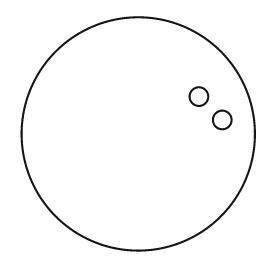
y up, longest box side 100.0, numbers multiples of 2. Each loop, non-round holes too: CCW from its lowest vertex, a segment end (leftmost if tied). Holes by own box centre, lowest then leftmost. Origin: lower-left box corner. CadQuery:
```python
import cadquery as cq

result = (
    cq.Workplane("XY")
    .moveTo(50.0, 50.0)
    .circle(50.0)
    .moveTo(86.0, 56.0)
    .circle(4.0)
    .moveTo(76.0, 66.0)
    .circle(4.0)
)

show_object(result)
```